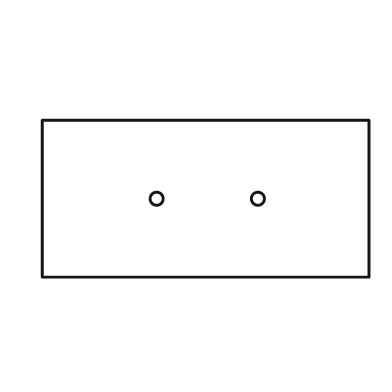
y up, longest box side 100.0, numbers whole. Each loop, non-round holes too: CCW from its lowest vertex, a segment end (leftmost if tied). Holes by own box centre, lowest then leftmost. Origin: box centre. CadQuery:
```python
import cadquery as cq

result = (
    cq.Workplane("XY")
    .moveTo(-50.0, -24.0)
    .lineTo(50.0, -24.0)
    .lineTo(50.0, 24.0)
    .lineTo(-50.0, 24.0)
    .close()
    .moveTo(-15.0, 0.0)
    .circle(2.0)
    .moveTo(16.0, 0.0)
    .circle(2.0)
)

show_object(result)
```